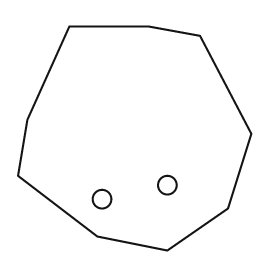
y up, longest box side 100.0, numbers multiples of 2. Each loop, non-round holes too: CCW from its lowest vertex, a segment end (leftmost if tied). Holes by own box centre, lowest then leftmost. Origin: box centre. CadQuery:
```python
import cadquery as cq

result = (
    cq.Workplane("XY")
    .moveTo(14.0, -48.0)
    .lineTo(40.0, -30.0)
    .lineTo(50.0, 2.0)
    .lineTo(28.0, 44.0)
    .lineTo(6.0, 48.0)
    .lineTo(-28.0, 48.0)
    .lineTo(-46.0, 8.0)
    .lineTo(-50.0, -16.0)
    .lineTo(-16.0, -42.0)
    .close()
    .moveTo(-14.0, -26.0)
    .circle(4.0)
    .moveTo(14.0, -20.0)
    .circle(4.0)
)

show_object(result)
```